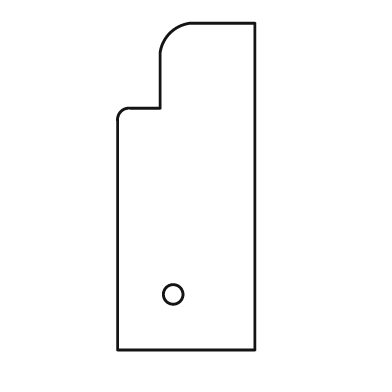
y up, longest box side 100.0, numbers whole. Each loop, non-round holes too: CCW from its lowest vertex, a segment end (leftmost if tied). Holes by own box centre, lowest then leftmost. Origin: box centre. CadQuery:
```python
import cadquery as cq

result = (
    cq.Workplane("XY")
    .moveTo(-21.0, -50.0)
    .lineTo(21.0, -50.0)
    .lineTo(21.0, 50.0)
    .lineTo(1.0, 50.0)
    .threePointArc((-5.0, 47.0), (-8.0, 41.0))
    .lineTo(-8.0, 24.0)
    .lineTo(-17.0, 24.0)
    .threePointArc((-20.0, 23.0), (-21.0, 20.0))
    .close()
    .moveTo(-4.0, -33.0)
    .circle(3.0)
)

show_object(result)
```